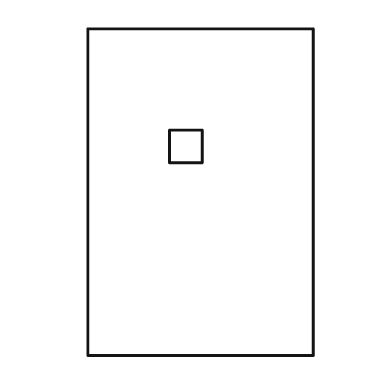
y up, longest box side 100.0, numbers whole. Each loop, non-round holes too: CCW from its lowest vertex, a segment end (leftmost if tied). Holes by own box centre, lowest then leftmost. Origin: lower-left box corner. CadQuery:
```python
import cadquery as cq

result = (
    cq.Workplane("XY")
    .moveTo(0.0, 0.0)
    .lineTo(69.0, 0.0)
    .lineTo(69.0, 100.0)
    .lineTo(0.0, 100.0)
    .close()
    .moveTo(25.0, 59.0)
    .lineTo(35.0, 59.0)
    .lineTo(35.0, 69.0)
    .lineTo(25.0, 69.0)
    .close()
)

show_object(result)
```